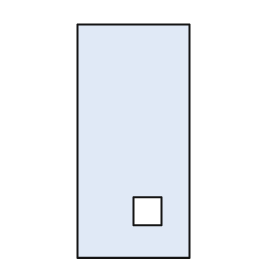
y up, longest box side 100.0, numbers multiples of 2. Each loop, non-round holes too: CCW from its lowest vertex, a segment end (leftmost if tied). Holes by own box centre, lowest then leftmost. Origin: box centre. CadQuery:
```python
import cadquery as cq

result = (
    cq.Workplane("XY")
    .moveTo(-24.0, -50.0)
    .lineTo(24.0, -50.0)
    .lineTo(24.0, 50.0)
    .lineTo(-24.0, 50.0)
    .close()
    .moveTo(0.0, -36.0)
    .lineTo(12.0, -36.0)
    .lineTo(12.0, -24.0)
    .lineTo(0.0, -24.0)
    .close()
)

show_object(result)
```